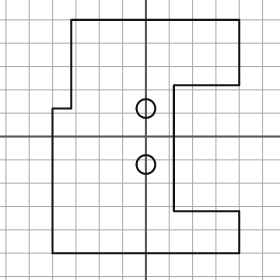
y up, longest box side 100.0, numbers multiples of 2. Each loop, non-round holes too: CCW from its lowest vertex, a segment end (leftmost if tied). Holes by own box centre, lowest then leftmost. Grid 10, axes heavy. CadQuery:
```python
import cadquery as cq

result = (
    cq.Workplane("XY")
    .moveTo(-40.0, -50.0)
    .lineTo(40.0, -50.0)
    .lineTo(40.0, -32.0)
    .lineTo(12.0, -32.0)
    .lineTo(12.0, 22.0)
    .lineTo(40.0, 22.0)
    .lineTo(40.0, 50.0)
    .lineTo(-32.0, 50.0)
    .lineTo(-32.0, 12.0)
    .lineTo(-40.0, 12.0)
    .close()
    .moveTo(0.0, -12.0)
    .circle(4.0)
    .moveTo(0.0, 12.0)
    .circle(4.0)
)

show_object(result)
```